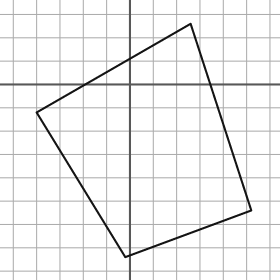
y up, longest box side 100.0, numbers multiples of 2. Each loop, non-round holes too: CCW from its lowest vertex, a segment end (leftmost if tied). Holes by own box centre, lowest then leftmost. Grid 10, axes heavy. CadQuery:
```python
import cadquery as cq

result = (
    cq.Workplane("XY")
    .moveTo(-2.0, -74.0)
    .lineTo(52.0, -54.0)
    .lineTo(26.0, 26.0)
    .lineTo(-40.0, -12.0)
    .close()
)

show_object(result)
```